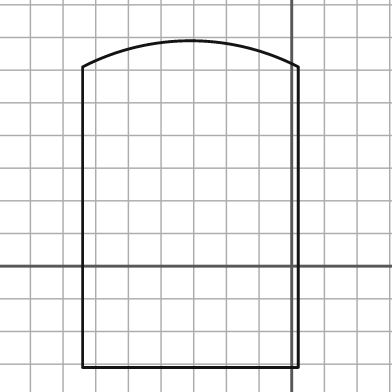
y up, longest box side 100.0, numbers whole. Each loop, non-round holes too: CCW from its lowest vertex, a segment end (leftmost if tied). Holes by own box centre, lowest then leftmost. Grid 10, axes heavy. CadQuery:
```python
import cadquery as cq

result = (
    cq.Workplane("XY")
    .moveTo(-64.0, -31.0)
    .lineTo(2.0, -31.0)
    .lineTo(2.0, 61.0)
    .threePointArc((-31.0, 69.0), (-64.0, 61.0))
    .close()
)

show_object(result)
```